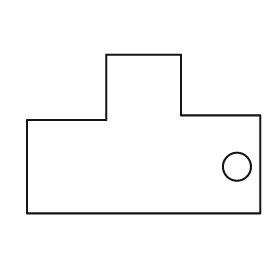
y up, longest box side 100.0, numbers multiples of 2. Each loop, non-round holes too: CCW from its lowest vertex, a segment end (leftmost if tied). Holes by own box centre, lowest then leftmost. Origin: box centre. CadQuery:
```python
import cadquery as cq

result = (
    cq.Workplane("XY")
    .moveTo(-50.0, -34.0)
    .lineTo(50.0, -34.0)
    .lineTo(50.0, 8.0)
    .lineTo(16.0, 8.0)
    .lineTo(16.0, 34.0)
    .lineTo(-16.0, 34.0)
    .lineTo(-16.0, 6.0)
    .lineTo(-50.0, 6.0)
    .close()
    .moveTo(40.0, -14.0)
    .circle(6.0)
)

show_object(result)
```